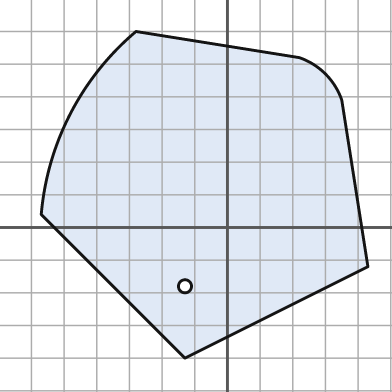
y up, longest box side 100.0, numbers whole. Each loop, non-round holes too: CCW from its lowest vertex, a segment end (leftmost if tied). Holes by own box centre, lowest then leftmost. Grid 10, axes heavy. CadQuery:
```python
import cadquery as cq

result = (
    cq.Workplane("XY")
    .moveTo(-13.0, -40.0)
    .lineTo(43.0, -12.0)
    .lineTo(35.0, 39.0)
    .threePointArc((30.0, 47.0), (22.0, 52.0))
    .lineTo(-28.0, 60.0)
    .threePointArc((-48.0, 35.0), (-57.0, 4.0))
    .close()
    .moveTo(-13.0, -18.0)
    .circle(2.0)
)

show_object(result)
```